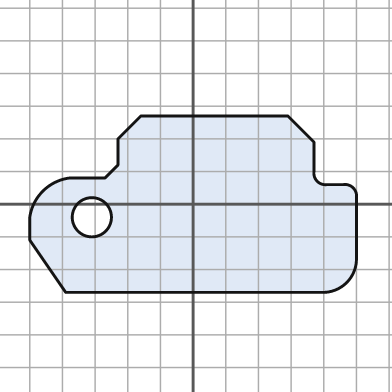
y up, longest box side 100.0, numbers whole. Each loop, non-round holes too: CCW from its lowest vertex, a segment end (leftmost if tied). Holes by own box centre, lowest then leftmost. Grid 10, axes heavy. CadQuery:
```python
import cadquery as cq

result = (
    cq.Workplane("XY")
    .moveTo(-39.0, -27.0)
    .lineTo(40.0, -27.0)
    .threePointArc((47.0, -24.0), (50.0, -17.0))
    .lineTo(50.0, 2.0)
    .threePointArc((49.0, 5.0), (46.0, 6.0))
    .lineTo(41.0, 6.0)
    .threePointArc((38.0, 7.0), (37.0, 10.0))
    .lineTo(37.0, 19.0)
    .lineTo(29.0, 27.0)
    .lineTo(-16.0, 27.0)
    .lineTo(-23.0, 20.0)
    .lineTo(-23.0, 12.0)
    .lineTo(-27.0, 8.0)
    .lineTo(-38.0, 8.0)
    .threePointArc((-46.0, 4.0), (-50.0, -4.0))
    .lineTo(-50.0, -11.0)
    .close()
    .moveTo(-31.0, -4.0)
    .circle(6.0)
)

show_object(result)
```